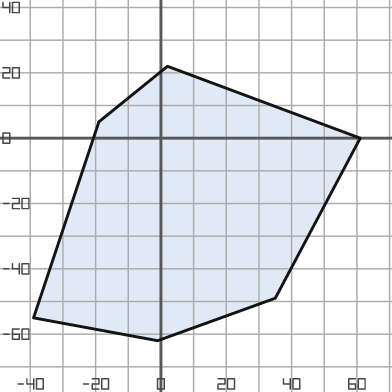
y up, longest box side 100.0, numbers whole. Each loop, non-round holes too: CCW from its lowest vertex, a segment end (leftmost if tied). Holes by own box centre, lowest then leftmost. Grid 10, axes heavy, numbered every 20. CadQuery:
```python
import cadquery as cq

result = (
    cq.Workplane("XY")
    .moveTo(-1.0, -62.0)
    .lineTo(35.0, -49.0)
    .lineTo(61.0, 0.0)
    .lineTo(2.0, 22.0)
    .lineTo(-19.0, 5.0)
    .lineTo(-39.0, -55.0)
    .close()
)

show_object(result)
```